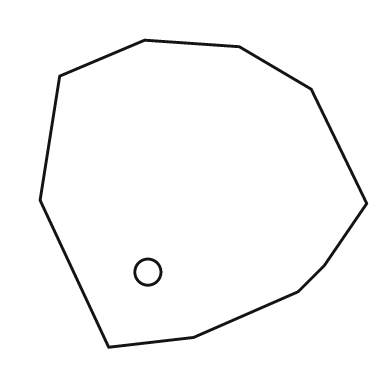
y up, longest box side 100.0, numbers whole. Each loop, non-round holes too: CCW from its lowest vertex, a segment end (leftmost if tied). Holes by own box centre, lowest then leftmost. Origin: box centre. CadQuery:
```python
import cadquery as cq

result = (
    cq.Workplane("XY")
    .moveTo(-29.0, -47.0)
    .lineTo(-3.0, -44.0)
    .lineTo(29.0, -30.0)
    .lineTo(37.0, -22.0)
    .lineTo(50.0, -3.0)
    .lineTo(33.0, 32.0)
    .lineTo(11.0, 45.0)
    .lineTo(-18.0, 47.0)
    .lineTo(-44.0, 36.0)
    .lineTo(-50.0, -2.0)
    .close()
    .moveTo(-17.0, -24.0)
    .circle(4.0)
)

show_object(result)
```